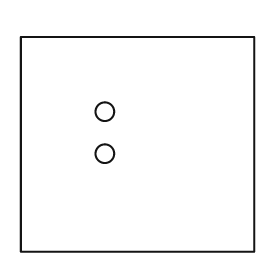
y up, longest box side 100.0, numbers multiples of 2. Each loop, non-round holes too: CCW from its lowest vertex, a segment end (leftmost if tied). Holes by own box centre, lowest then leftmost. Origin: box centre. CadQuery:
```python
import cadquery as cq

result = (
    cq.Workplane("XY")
    .moveTo(-50.0, -46.0)
    .lineTo(50.0, -46.0)
    .lineTo(50.0, 46.0)
    .lineTo(-50.0, 46.0)
    .close()
    .moveTo(-14.0, -4.0)
    .circle(4.0)
    .moveTo(-14.0, 14.0)
    .circle(4.0)
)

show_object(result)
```